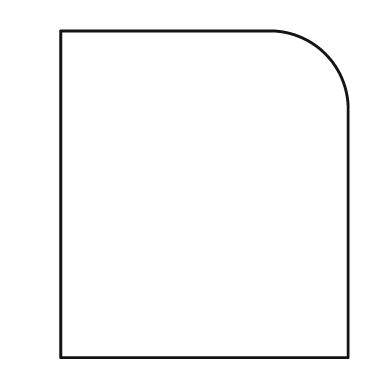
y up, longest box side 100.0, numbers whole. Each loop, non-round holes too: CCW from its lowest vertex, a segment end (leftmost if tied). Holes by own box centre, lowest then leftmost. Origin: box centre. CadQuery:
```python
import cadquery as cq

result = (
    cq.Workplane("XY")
    .moveTo(-44.0, -50.0)
    .lineTo(44.0, -50.0)
    .lineTo(44.0, 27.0)
    .threePointArc((37.0, 43.0), (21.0, 50.0))
    .lineTo(-44.0, 50.0)
    .close()
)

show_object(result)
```